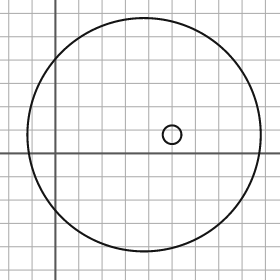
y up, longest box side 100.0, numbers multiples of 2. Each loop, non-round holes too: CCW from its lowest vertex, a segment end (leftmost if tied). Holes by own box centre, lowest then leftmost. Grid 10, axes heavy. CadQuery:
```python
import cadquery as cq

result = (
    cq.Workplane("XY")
    .moveTo(38.0, 8.0)
    .circle(50.0)
    .moveTo(50.0, 8.0)
    .circle(4.0)
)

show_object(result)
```